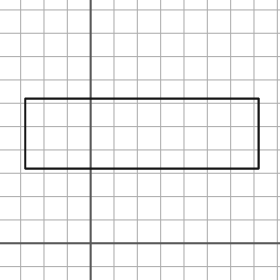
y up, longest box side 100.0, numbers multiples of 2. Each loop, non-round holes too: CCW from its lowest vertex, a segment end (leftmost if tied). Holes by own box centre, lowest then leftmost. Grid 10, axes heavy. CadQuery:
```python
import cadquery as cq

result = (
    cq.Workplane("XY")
    .moveTo(-28.0, 32.0)
    .lineTo(72.0, 32.0)
    .lineTo(72.0, 62.0)
    .lineTo(-28.0, 62.0)
    .close()
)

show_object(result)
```